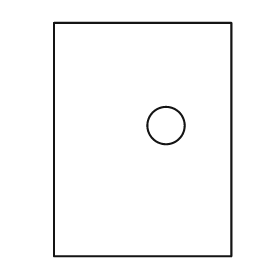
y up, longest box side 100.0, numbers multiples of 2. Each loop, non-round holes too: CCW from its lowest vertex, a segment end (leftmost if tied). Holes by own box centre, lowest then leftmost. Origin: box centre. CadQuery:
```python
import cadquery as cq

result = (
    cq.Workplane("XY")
    .moveTo(-38.0, -50.0)
    .lineTo(38.0, -50.0)
    .lineTo(38.0, 50.0)
    .lineTo(-38.0, 50.0)
    .close()
    .moveTo(10.0, 6.0)
    .circle(8.0)
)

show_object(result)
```